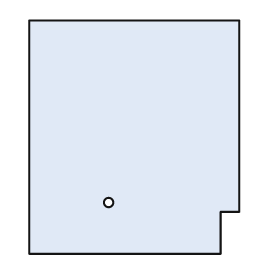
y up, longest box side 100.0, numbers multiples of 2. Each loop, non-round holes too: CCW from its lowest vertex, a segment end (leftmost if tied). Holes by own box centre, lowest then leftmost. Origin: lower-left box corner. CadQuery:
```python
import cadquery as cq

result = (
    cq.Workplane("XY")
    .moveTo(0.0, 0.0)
    .lineTo(82.0, 0.0)
    .lineTo(82.0, 18.0)
    .lineTo(90.0, 18.0)
    .lineTo(90.0, 100.0)
    .lineTo(0.0, 100.0)
    .close()
    .moveTo(34.0, 22.0)
    .circle(2.0)
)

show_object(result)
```